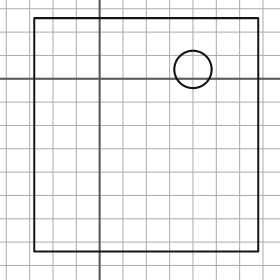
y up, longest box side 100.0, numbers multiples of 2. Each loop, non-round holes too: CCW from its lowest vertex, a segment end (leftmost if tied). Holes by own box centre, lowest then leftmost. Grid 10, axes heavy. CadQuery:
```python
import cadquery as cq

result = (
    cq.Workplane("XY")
    .moveTo(-28.0, -74.0)
    .lineTo(68.0, -74.0)
    .lineTo(68.0, 26.0)
    .lineTo(-28.0, 26.0)
    .close()
    .moveTo(40.0, 4.0)
    .circle(8.0)
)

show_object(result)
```